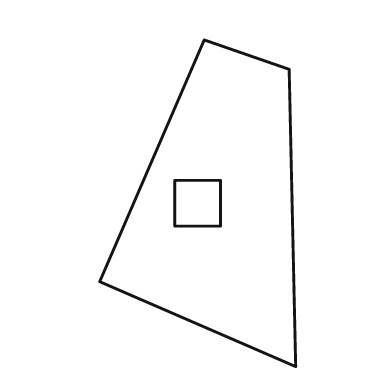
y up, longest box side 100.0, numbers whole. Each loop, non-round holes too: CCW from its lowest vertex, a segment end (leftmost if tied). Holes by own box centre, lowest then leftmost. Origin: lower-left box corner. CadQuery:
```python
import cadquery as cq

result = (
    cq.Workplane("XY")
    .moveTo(60.0, 0.0)
    .lineTo(58.0, 91.0)
    .lineTo(32.0, 100.0)
    .lineTo(0.0, 26.0)
    .close()
    .moveTo(23.0, 43.0)
    .lineTo(37.0, 43.0)
    .lineTo(37.0, 57.0)
    .lineTo(23.0, 57.0)
    .close()
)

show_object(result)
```